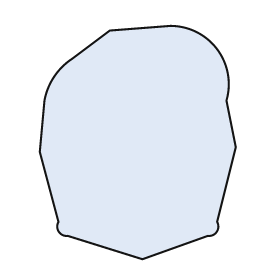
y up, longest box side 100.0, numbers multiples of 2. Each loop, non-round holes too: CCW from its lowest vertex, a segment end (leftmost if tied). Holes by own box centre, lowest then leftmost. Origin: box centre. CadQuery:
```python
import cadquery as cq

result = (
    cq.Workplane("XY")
    .moveTo(2.0, -50.0)
    .lineTo(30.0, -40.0)
    .threePointArc((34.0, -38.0), (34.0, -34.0))
    .lineTo(42.0, -2.0)
    .lineTo(38.0, 18.0)
    .threePointArc((34.0, 40.0), (14.0, 50.0))
    .lineTo(-12.0, 48.0)
    .lineTo(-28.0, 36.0)
    .threePointArc((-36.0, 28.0), (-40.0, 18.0))
    .lineTo(-42.0, -4.0)
    .lineTo(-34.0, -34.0)
    .threePointArc((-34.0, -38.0), (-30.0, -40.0))
    .close()
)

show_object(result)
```